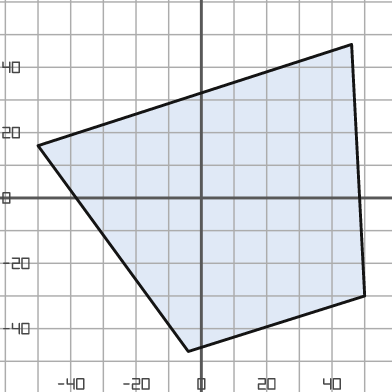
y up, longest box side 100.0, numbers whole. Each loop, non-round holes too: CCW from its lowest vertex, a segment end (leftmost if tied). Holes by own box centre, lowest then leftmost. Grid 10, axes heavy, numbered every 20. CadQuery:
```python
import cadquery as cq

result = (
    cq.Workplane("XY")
    .moveTo(-4.0, -47.0)
    .lineTo(50.0, -30.0)
    .lineTo(46.0, 47.0)
    .lineTo(-50.0, 16.0)
    .close()
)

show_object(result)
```